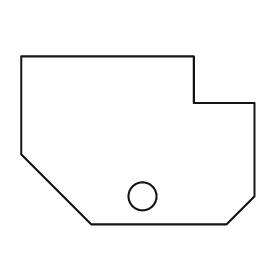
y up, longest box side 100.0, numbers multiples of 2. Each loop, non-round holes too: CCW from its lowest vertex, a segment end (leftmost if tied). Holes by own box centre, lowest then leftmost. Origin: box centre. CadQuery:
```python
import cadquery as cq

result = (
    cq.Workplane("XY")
    .moveTo(-20.0, -36.0)
    .lineTo(38.0, -36.0)
    .lineTo(50.0, -24.0)
    .lineTo(50.0, 16.0)
    .lineTo(24.0, 16.0)
    .lineTo(24.0, 36.0)
    .lineTo(-50.0, 36.0)
    .lineTo(-50.0, -6.0)
    .close()
    .moveTo(2.0, -24.0)
    .circle(6.0)
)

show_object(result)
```